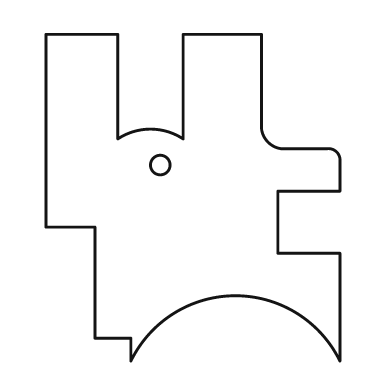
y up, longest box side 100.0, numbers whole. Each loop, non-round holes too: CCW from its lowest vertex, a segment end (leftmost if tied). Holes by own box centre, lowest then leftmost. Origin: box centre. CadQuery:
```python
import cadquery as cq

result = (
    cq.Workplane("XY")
    .moveTo(-19.0, -50.0)
    .threePointArc((13.0, -30.0), (45.0, -50.0))
    .lineTo(45.0, -17.0)
    .lineTo(26.0, -17.0)
    .lineTo(26.0, 2.0)
    .lineTo(45.0, 2.0)
    .lineTo(45.0, 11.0)
    .threePointArc((44.0, 14.0), (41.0, 15.0))
    .lineTo(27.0, 15.0)
    .threePointArc((23.0, 17.0), (21.0, 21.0))
    .lineTo(21.0, 50.0)
    .lineTo(-3.0, 50.0)
    .lineTo(-3.0, 18.0)
    .threePointArc((-13.0, 21.0), (-23.0, 18.0))
    .lineTo(-23.0, 50.0)
    .lineTo(-45.0, 50.0)
    .lineTo(-45.0, -9.0)
    .lineTo(-30.0, -9.0)
    .lineTo(-30.0, -43.0)
    .lineTo(-19.0, -43.0)
    .close()
    .moveTo(-10.0, 10.0)
    .circle(3.0)
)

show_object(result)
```